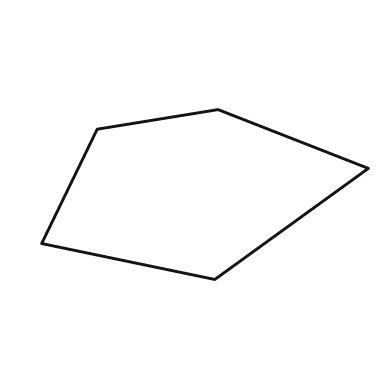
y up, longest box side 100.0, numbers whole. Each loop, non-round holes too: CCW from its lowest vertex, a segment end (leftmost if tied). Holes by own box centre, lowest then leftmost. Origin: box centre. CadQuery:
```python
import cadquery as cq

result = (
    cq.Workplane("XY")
    .moveTo(3.0, -26.0)
    .lineTo(50.0, 8.0)
    .lineTo(4.0, 26.0)
    .lineTo(-33.0, 20.0)
    .lineTo(-50.0, -15.0)
    .close()
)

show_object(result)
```